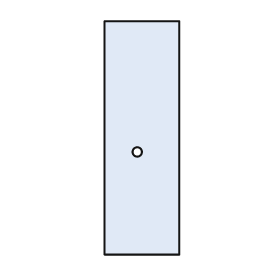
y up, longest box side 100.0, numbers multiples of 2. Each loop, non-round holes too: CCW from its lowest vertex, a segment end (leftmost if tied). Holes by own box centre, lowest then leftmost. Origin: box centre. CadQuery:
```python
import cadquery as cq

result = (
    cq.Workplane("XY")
    .moveTo(-16.0, -50.0)
    .lineTo(16.0, -50.0)
    .lineTo(16.0, 50.0)
    .lineTo(-16.0, 50.0)
    .close()
    .moveTo(-2.0, -6.0)
    .circle(2.0)
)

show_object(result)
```